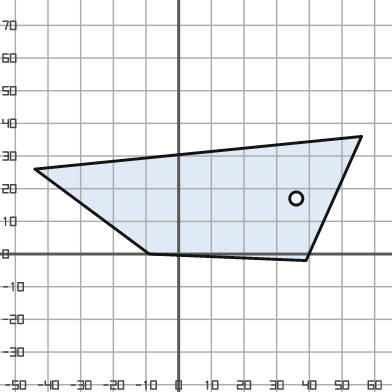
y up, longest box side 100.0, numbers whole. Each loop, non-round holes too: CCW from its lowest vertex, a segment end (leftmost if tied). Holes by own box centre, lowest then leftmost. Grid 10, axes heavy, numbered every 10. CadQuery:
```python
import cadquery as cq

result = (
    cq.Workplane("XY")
    .moveTo(39.0, -2.0)
    .lineTo(56.0, 36.0)
    .lineTo(-44.0, 26.0)
    .lineTo(-9.0, 0.0)
    .close()
    .moveTo(36.0, 17.0)
    .circle(2.0)
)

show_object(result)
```